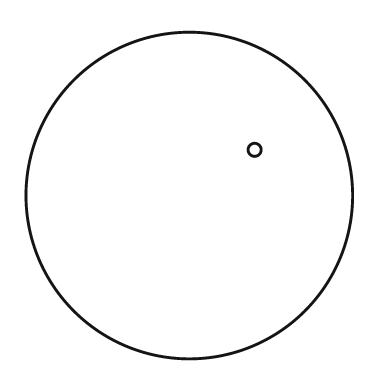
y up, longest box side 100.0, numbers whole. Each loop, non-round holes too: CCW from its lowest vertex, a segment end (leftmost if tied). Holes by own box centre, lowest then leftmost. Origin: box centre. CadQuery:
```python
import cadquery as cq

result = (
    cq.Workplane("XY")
    .moveTo(0.0, 0.0)
    .circle(50.0)
    .moveTo(20.0, 14.0)
    .circle(2.0)
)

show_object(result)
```